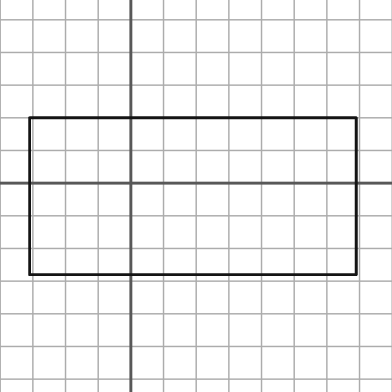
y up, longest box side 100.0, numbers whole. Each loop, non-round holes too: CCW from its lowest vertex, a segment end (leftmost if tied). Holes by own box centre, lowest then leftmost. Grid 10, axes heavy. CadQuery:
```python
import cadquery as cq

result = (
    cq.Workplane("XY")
    .moveTo(-31.0, -28.0)
    .lineTo(69.0, -28.0)
    .lineTo(69.0, 20.0)
    .lineTo(-31.0, 20.0)
    .close()
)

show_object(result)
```